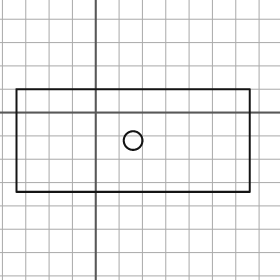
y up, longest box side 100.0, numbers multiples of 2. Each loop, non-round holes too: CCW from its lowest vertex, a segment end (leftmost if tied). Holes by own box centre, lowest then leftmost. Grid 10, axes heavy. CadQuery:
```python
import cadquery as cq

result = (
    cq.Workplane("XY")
    .moveTo(-34.0, -34.0)
    .lineTo(66.0, -34.0)
    .lineTo(66.0, 10.0)
    .lineTo(-34.0, 10.0)
    .close()
    .moveTo(16.0, -12.0)
    .circle(4.0)
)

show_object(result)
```